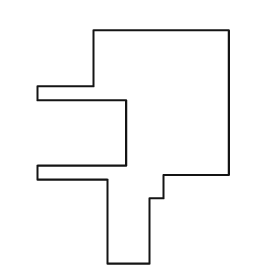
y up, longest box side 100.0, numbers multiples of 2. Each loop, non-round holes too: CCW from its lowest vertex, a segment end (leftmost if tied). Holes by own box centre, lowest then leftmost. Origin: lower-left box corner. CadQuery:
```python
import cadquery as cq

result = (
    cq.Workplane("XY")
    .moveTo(30.0, 0.0)
    .lineTo(48.0, 0.0)
    .lineTo(48.0, 28.0)
    .lineTo(54.0, 28.0)
    .lineTo(54.0, 38.0)
    .lineTo(82.0, 38.0)
    .lineTo(82.0, 100.0)
    .lineTo(24.0, 100.0)
    .lineTo(24.0, 76.0)
    .lineTo(0.0, 76.0)
    .lineTo(0.0, 70.0)
    .lineTo(38.0, 70.0)
    .lineTo(38.0, 42.0)
    .lineTo(0.0, 42.0)
    .lineTo(0.0, 36.0)
    .lineTo(30.0, 36.0)
    .close()
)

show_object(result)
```